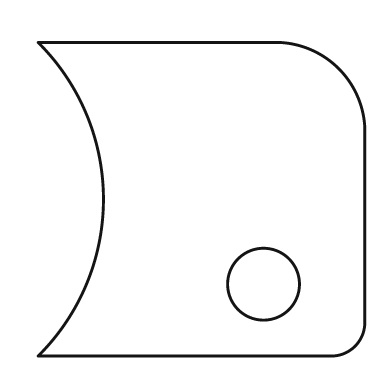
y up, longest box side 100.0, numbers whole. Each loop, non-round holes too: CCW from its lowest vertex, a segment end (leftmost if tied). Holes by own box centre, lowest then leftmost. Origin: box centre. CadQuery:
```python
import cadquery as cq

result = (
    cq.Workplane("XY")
    .moveTo(-50.0, -48.0)
    .lineTo(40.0, -48.0)
    .threePointArc((47.0, -45.0), (50.0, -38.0))
    .lineTo(50.0, 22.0)
    .threePointArc((42.0, 40.0), (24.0, 48.0))
    .lineTo(-50.0, 48.0)
    .threePointArc((-30.0, 0.0), (-50.0, -48.0))
    .close()
    .moveTo(19.0, -26.0)
    .circle(11.0)
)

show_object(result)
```